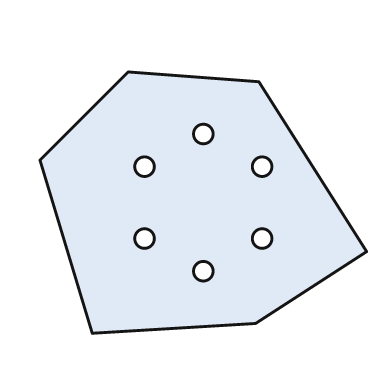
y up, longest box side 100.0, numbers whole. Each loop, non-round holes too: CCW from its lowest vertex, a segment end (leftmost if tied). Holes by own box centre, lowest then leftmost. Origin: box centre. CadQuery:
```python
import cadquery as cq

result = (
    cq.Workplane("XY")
    .moveTo(-34.0, -40.0)
    .lineTo(16.0, -37.0)
    .lineTo(50.0, -15.0)
    .lineTo(17.0, 37.0)
    .lineTo(-23.0, 40.0)
    .lineTo(-50.0, 13.0)
    .close()
    .moveTo(0.0, -21.0)
    .circle(3.0)
    .moveTo(-18.0, -11.0)
    .circle(3.0)
    .moveTo(18.0, -11.0)
    .circle(3.0)
    .moveTo(-18.0, 11.0)
    .circle(3.0)
    .moveTo(18.0, 11.0)
    .circle(3.0)
    .moveTo(0.0, 21.0)
    .circle(3.0)
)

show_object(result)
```